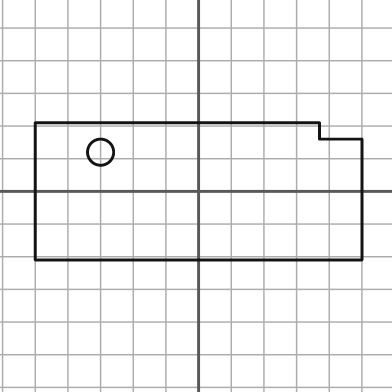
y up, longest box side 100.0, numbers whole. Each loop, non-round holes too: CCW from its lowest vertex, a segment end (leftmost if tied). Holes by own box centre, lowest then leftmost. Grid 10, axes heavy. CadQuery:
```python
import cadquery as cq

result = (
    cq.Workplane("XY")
    .moveTo(-50.0, -21.0)
    .lineTo(50.0, -21.0)
    .lineTo(50.0, 16.0)
    .lineTo(37.0, 16.0)
    .lineTo(37.0, 21.0)
    .lineTo(-50.0, 21.0)
    .close()
    .moveTo(-30.0, 12.0)
    .circle(4.0)
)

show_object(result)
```